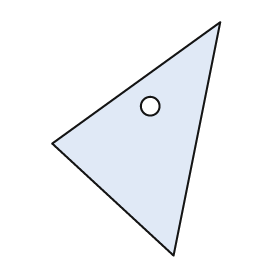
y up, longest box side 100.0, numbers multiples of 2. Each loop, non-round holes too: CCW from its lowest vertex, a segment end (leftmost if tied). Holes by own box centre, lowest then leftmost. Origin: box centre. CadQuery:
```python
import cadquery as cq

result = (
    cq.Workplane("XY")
    .moveTo(16.0, -50.0)
    .lineTo(36.0, 50.0)
    .lineTo(-36.0, -2.0)
    .close()
    .moveTo(6.0, 14.0)
    .circle(4.0)
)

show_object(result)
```